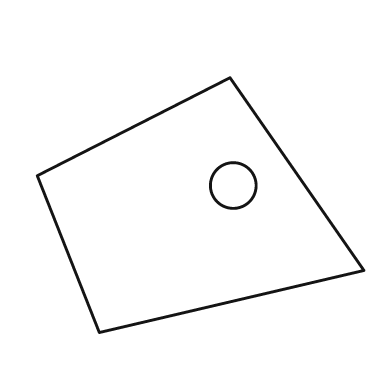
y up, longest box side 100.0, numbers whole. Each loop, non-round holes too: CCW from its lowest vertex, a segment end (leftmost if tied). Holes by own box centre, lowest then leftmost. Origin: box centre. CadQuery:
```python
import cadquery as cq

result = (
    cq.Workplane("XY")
    .moveTo(-31.0, -39.0)
    .lineTo(50.0, -20.0)
    .lineTo(9.0, 39.0)
    .lineTo(-50.0, 9.0)
    .close()
    .moveTo(10.0, 6.0)
    .circle(7.0)
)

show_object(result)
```